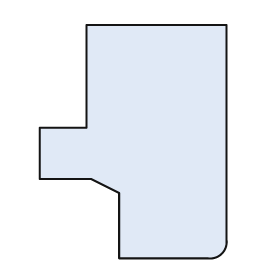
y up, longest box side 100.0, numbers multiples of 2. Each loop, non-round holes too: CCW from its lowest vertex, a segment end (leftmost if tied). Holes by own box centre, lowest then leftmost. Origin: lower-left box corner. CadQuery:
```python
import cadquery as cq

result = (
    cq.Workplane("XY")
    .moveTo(34.0, 0.0)
    .lineTo(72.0, 0.0)
    .threePointArc((78.0, 2.0), (80.0, 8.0))
    .lineTo(80.0, 100.0)
    .lineTo(20.0, 100.0)
    .lineTo(20.0, 56.0)
    .lineTo(0.0, 56.0)
    .lineTo(0.0, 34.0)
    .lineTo(22.0, 34.0)
    .lineTo(34.0, 28.0)
    .close()
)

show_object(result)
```